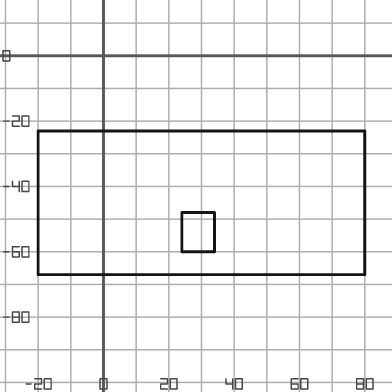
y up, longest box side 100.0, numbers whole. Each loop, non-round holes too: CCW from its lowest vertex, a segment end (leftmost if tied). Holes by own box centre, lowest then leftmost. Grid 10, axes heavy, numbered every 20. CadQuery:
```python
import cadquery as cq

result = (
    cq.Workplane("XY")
    .moveTo(-20.0, -67.0)
    .lineTo(80.0, -67.0)
    .lineTo(80.0, -23.0)
    .lineTo(-20.0, -23.0)
    .close()
    .moveTo(24.0, -60.0)
    .lineTo(34.0, -60.0)
    .lineTo(34.0, -48.0)
    .lineTo(24.0, -48.0)
    .close()
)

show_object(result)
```